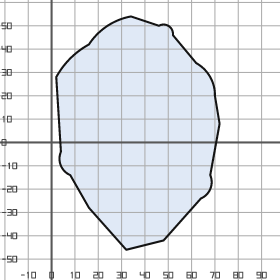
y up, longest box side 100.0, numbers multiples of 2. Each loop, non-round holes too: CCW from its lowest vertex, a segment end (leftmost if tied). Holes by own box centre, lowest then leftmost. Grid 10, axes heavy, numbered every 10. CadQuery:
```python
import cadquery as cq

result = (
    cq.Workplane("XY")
    .moveTo(32.0, -46.0)
    .lineTo(48.0, -42.0)
    .lineTo(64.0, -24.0)
    .threePointArc((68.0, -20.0), (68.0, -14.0))
    .lineTo(72.0, 8.0)
    .lineTo(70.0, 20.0)
    .threePointArc((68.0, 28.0), (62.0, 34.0))
    .lineTo(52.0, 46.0)
    .threePointArc((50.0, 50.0), (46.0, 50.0))
    .lineTo(34.0, 54.0)
    .threePointArc((24.0, 50.0), (16.0, 42.0))
    .threePointArc((8.0, 36.0), (2.0, 28.0))
    .lineTo(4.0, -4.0)
    .threePointArc((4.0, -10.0), (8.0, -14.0))
    .lineTo(16.0, -28.0)
    .close()
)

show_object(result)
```